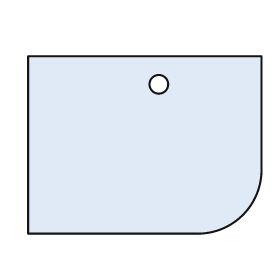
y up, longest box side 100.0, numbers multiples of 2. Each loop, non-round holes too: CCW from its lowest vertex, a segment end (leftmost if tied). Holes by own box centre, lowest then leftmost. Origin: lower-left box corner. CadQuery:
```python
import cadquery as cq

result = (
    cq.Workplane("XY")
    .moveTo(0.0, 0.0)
    .lineTo(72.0, 0.0)
    .threePointArc((92.0, 8.0), (100.0, 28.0))
    .lineTo(100.0, 76.0)
    .lineTo(0.0, 76.0)
    .close()
    .moveTo(56.0, 64.0)
    .circle(4.0)
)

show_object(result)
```